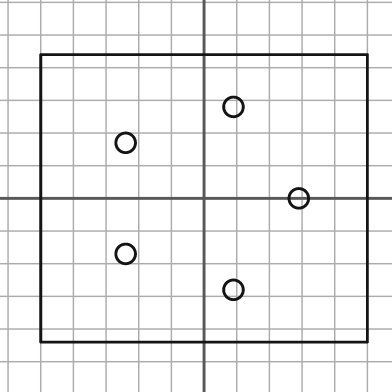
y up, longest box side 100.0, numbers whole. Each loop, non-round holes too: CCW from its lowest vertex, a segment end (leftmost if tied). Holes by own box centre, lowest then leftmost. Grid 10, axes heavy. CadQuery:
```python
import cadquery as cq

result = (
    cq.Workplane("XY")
    .moveTo(-50.0, -44.0)
    .lineTo(50.0, -44.0)
    .lineTo(50.0, 44.0)
    .lineTo(-50.0, 44.0)
    .close()
    .moveTo(9.0, -28.0)
    .circle(3.0)
    .moveTo(-24.0, -17.0)
    .circle(3.0)
    .moveTo(29.0, 0.0)
    .circle(3.0)
    .moveTo(-24.0, 17.0)
    .circle(3.0)
    .moveTo(9.0, 28.0)
    .circle(3.0)
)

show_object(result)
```